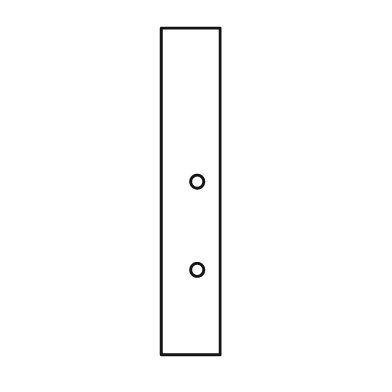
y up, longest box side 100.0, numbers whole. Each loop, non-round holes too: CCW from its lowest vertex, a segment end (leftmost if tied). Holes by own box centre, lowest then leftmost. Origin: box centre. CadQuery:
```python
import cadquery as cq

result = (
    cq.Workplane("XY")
    .moveTo(-9.0, -50.0)
    .lineTo(9.0, -50.0)
    .lineTo(9.0, 50.0)
    .lineTo(-9.0, 50.0)
    .close()
    .moveTo(2.0, -24.0)
    .circle(2.0)
    .moveTo(2.0, 3.0)
    .circle(2.0)
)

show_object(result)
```